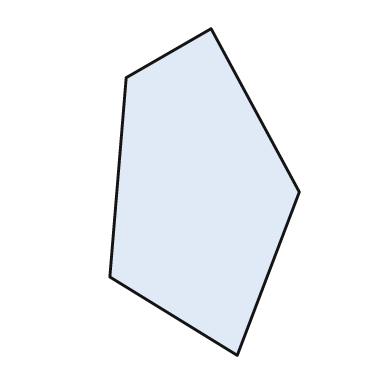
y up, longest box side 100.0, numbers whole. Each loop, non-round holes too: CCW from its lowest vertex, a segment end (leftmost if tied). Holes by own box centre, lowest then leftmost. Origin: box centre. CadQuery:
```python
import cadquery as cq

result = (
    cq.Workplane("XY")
    .moveTo(10.0, -50.0)
    .lineTo(29.0, 0.0)
    .lineTo(2.0, 50.0)
    .lineTo(-24.0, 35.0)
    .lineTo(-29.0, -26.0)
    .close()
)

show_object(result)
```